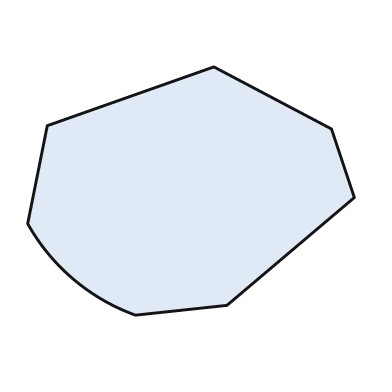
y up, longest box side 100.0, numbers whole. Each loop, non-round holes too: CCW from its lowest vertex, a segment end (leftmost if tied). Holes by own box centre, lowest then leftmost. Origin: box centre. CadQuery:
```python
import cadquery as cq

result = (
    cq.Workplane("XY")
    .moveTo(-17.0, -38.0)
    .lineTo(11.0, -35.0)
    .lineTo(50.0, -2.0)
    .lineTo(43.0, 19.0)
    .lineTo(7.0, 38.0)
    .lineTo(-44.0, 20.0)
    .lineTo(-50.0, -10.0)
    .threePointArc((-36.0, -27.0), (-17.0, -38.0))
    .close()
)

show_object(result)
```